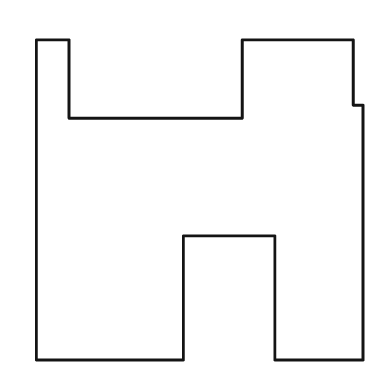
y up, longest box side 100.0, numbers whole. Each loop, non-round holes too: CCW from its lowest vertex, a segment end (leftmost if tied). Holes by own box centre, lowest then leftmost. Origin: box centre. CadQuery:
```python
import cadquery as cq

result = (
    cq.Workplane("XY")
    .moveTo(-50.0, -49.0)
    .lineTo(-5.0, -49.0)
    .lineTo(-5.0, -11.0)
    .lineTo(23.0, -11.0)
    .lineTo(23.0, -49.0)
    .lineTo(50.0, -49.0)
    .lineTo(50.0, 29.0)
    .lineTo(47.0, 29.0)
    .lineTo(47.0, 49.0)
    .lineTo(13.0, 49.0)
    .lineTo(13.0, 25.0)
    .lineTo(-40.0, 25.0)
    .lineTo(-40.0, 49.0)
    .lineTo(-50.0, 49.0)
    .close()
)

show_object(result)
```